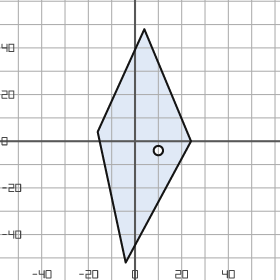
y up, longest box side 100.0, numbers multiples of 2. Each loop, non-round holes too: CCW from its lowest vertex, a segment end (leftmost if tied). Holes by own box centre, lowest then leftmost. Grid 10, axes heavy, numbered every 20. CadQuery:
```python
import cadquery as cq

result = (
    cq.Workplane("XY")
    .moveTo(-4.0, -52.0)
    .lineTo(24.0, 0.0)
    .lineTo(4.0, 48.0)
    .lineTo(-16.0, 4.0)
    .close()
    .moveTo(10.0, -4.0)
    .circle(2.0)
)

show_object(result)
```